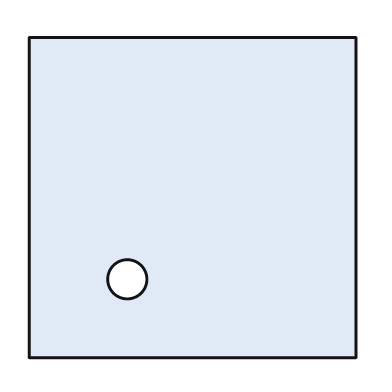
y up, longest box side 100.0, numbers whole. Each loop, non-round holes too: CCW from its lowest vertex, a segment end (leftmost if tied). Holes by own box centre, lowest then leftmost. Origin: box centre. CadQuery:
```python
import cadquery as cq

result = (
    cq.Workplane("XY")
    .moveTo(-50.0, -49.0)
    .lineTo(50.0, -49.0)
    .lineTo(50.0, 49.0)
    .lineTo(-50.0, 49.0)
    .close()
    .moveTo(-20.0, -25.0)
    .circle(6.0)
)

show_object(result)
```